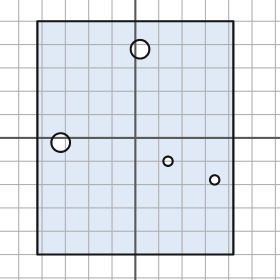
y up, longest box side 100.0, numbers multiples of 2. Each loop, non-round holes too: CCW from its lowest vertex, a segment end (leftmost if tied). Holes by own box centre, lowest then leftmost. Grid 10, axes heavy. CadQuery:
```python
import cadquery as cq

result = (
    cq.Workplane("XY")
    .moveTo(-42.0, -50.0)
    .lineTo(42.0, -50.0)
    .lineTo(42.0, 50.0)
    .lineTo(-42.0, 50.0)
    .close()
    .moveTo(34.0, -18.0)
    .circle(2.0)
    .moveTo(14.0, -10.0)
    .circle(2.0)
    .moveTo(-32.0, -2.0)
    .circle(4.0)
    .moveTo(2.0, 38.0)
    .circle(4.0)
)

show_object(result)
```